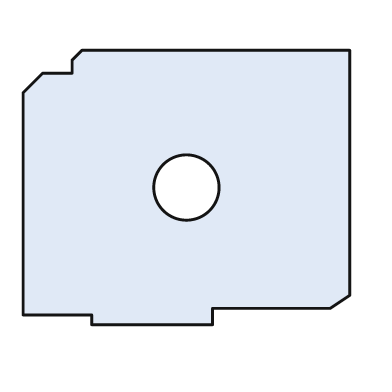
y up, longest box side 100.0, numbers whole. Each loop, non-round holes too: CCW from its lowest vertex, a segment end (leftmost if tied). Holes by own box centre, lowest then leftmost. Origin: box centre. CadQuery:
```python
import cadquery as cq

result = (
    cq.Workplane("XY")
    .moveTo(-29.0, -42.0)
    .lineTo(8.0, -42.0)
    .lineTo(8.0, -37.0)
    .lineTo(44.0, -37.0)
    .lineTo(50.0, -33.0)
    .lineTo(50.0, 42.0)
    .lineTo(-32.0, 42.0)
    .lineTo(-35.0, 39.0)
    .lineTo(-35.0, 35.0)
    .lineTo(-44.0, 35.0)
    .lineTo(-50.0, 29.0)
    .lineTo(-50.0, -39.0)
    .lineTo(-29.0, -39.0)
    .close()
    .moveTo(0.0, 0.0)
    .circle(10.0)
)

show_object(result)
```